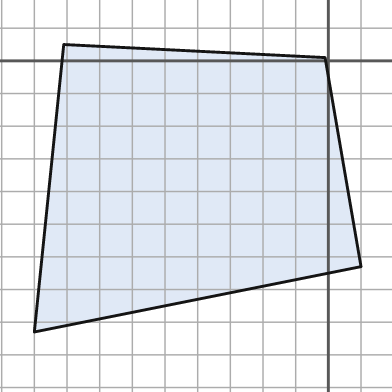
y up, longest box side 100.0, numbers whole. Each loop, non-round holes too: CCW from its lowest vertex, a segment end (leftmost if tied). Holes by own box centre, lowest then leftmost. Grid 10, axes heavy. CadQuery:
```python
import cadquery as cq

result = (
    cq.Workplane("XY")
    .moveTo(-90.0, -83.0)
    .lineTo(10.0, -63.0)
    .lineTo(-1.0, 1.0)
    .lineTo(-81.0, 5.0)
    .close()
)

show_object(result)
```